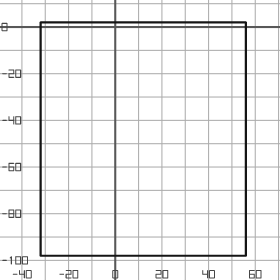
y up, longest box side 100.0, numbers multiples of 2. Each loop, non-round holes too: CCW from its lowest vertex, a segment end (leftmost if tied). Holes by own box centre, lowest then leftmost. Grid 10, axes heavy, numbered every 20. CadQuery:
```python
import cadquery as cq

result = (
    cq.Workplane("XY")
    .moveTo(-32.0, -98.0)
    .lineTo(56.0, -98.0)
    .lineTo(56.0, 2.0)
    .lineTo(-32.0, 2.0)
    .close()
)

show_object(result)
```